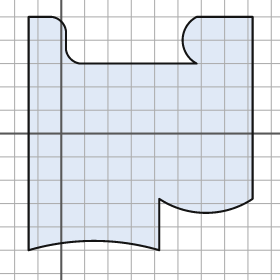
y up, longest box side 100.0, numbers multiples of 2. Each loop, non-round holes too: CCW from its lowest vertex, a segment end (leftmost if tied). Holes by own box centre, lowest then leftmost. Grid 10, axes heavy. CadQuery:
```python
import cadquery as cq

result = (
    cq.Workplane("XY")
    .moveTo(-14.0, -50.0)
    .threePointArc((14.0, -46.0), (42.0, -50.0))
    .lineTo(42.0, -28.0)
    .threePointArc((62.0, -34.0), (82.0, -28.0))
    .lineTo(82.0, 50.0)
    .lineTo(58.0, 50.0)
    .threePointArc((52.0, 40.0), (58.0, 30.0))
    .lineTo(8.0, 30.0)
    .threePointArc((4.0, 32.0), (2.0, 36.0))
    .lineTo(2.0, 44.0)
    .threePointArc((0.0, 48.0), (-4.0, 50.0))
    .lineTo(-14.0, 50.0)
    .close()
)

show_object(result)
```